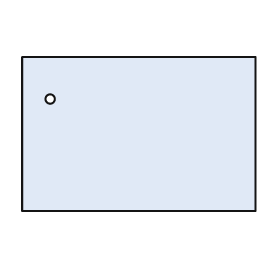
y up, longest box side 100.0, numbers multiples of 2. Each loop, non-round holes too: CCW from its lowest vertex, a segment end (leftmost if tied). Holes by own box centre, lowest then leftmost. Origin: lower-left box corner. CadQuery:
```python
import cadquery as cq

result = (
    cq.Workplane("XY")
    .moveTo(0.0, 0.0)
    .lineTo(100.0, 0.0)
    .lineTo(100.0, 66.0)
    .lineTo(0.0, 66.0)
    .close()
    .moveTo(12.0, 48.0)
    .circle(2.0)
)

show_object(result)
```